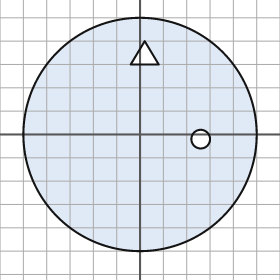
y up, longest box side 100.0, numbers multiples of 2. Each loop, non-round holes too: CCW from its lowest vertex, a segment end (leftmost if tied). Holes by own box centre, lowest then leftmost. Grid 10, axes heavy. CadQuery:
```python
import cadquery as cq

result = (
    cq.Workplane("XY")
    .moveTo(0.0, 0.0)
    .circle(50.0)
    .moveTo(26.0, -2.0)
    .circle(4.0)
    .moveTo(-4.0, 30.0)
    .lineTo(8.0, 30.0)
    .lineTo(2.0, 40.0)
    .close()
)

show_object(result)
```